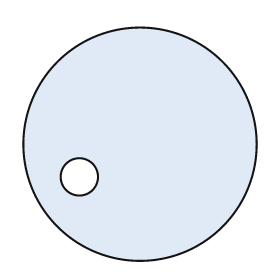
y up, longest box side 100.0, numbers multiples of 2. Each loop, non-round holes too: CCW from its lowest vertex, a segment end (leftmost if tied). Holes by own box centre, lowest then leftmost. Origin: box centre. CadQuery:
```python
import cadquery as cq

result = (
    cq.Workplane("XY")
    .moveTo(0.0, 0.0)
    .circle(50.0)
    .moveTo(-26.0, -14.0)
    .circle(8.0)
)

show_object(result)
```